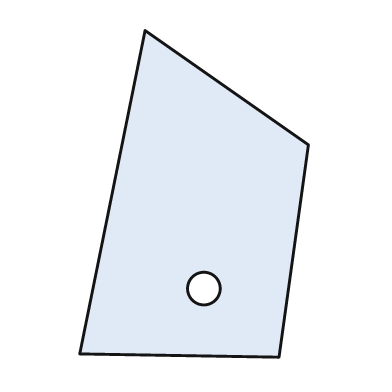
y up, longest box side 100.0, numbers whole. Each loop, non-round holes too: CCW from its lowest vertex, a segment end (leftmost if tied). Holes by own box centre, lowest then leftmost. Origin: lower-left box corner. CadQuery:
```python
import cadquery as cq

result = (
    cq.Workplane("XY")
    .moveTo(61.0, 0.0)
    .lineTo(70.0, 65.0)
    .lineTo(20.0, 100.0)
    .lineTo(0.0, 1.0)
    .close()
    .moveTo(38.0, 21.0)
    .circle(5.0)
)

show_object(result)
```